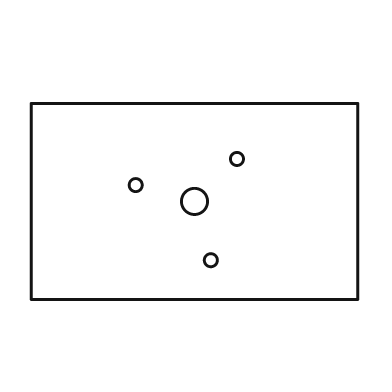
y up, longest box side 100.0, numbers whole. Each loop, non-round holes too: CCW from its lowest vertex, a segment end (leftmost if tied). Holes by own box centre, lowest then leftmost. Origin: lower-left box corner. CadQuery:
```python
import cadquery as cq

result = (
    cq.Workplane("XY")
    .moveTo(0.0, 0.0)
    .lineTo(100.0, 0.0)
    .lineTo(100.0, 60.0)
    .lineTo(0.0, 60.0)
    .close()
    .moveTo(55.0, 12.0)
    .circle(2.0)
    .moveTo(50.0, 30.0)
    .circle(4.0)
    .moveTo(32.0, 35.0)
    .circle(2.0)
    .moveTo(63.0, 43.0)
    .circle(2.0)
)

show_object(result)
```